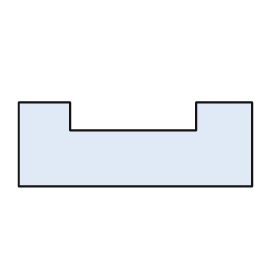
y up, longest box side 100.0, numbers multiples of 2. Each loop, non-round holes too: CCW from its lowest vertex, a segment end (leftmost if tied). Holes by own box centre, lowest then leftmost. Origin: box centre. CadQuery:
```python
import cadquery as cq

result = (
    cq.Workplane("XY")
    .moveTo(-50.0, -18.0)
    .lineTo(50.0, -18.0)
    .lineTo(50.0, 18.0)
    .lineTo(26.0, 18.0)
    .lineTo(26.0, 6.0)
    .lineTo(-28.0, 6.0)
    .lineTo(-28.0, 18.0)
    .lineTo(-50.0, 18.0)
    .close()
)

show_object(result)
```